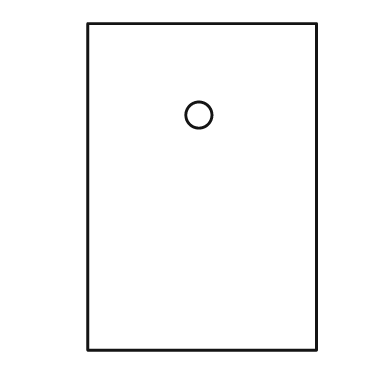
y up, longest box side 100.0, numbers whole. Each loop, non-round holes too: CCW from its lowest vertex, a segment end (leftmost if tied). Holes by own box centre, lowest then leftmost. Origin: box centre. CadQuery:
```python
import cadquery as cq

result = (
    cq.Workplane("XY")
    .moveTo(-35.0, -50.0)
    .lineTo(35.0, -50.0)
    .lineTo(35.0, 50.0)
    .lineTo(-35.0, 50.0)
    .close()
    .moveTo(-1.0, 22.0)
    .circle(4.0)
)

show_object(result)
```